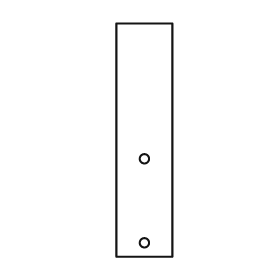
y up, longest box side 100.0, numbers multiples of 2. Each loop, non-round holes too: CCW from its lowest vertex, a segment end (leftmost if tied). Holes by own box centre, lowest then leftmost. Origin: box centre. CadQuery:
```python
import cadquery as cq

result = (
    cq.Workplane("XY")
    .moveTo(-12.0, -50.0)
    .lineTo(12.0, -50.0)
    .lineTo(12.0, 50.0)
    .lineTo(-12.0, 50.0)
    .close()
    .moveTo(0.0, -44.0)
    .circle(2.0)
    .moveTo(0.0, -8.0)
    .circle(2.0)
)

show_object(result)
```